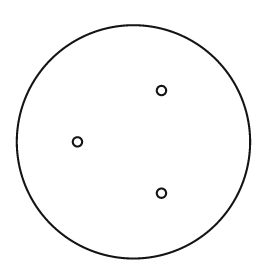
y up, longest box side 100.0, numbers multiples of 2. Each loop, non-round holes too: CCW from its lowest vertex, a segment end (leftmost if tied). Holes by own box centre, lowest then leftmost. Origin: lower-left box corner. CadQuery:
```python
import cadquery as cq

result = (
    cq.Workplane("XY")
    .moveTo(50.0, 50.0)
    .circle(50.0)
    .moveTo(62.0, 28.0)
    .circle(2.0)
    .moveTo(26.0, 50.0)
    .circle(2.0)
    .moveTo(62.0, 72.0)
    .circle(2.0)
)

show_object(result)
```